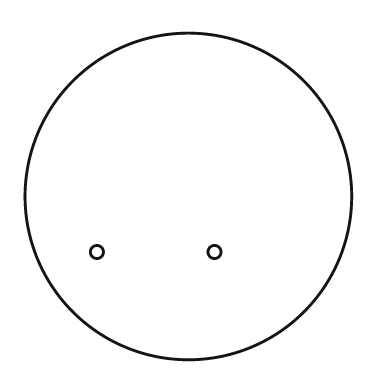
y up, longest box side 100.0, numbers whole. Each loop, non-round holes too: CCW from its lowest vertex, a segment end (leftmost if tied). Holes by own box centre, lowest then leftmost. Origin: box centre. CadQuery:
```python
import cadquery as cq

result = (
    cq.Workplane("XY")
    .moveTo(0.0, 0.0)
    .circle(50.0)
    .moveTo(-28.0, -17.0)
    .circle(2.0)
    .moveTo(8.0, -17.0)
    .circle(2.0)
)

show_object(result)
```